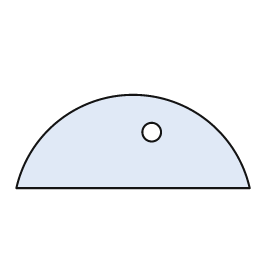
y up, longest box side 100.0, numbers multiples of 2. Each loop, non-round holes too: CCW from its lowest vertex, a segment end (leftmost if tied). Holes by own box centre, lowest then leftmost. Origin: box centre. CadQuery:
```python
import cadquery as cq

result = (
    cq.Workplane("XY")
    .moveTo(-50.0, -20.0)
    .lineTo(50.0, -20.0)
    .threePointArc((0.0, 20.0), (-50.0, -20.0))
    .close()
    .moveTo(8.0, 4.0)
    .circle(4.0)
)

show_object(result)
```